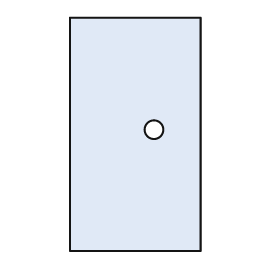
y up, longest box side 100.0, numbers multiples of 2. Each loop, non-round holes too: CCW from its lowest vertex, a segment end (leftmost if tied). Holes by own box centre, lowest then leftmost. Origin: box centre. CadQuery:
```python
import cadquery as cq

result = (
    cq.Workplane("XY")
    .moveTo(-28.0, -50.0)
    .lineTo(28.0, -50.0)
    .lineTo(28.0, 50.0)
    .lineTo(-28.0, 50.0)
    .close()
    .moveTo(8.0, 2.0)
    .circle(4.0)
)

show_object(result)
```